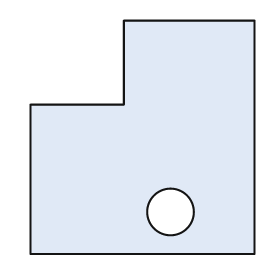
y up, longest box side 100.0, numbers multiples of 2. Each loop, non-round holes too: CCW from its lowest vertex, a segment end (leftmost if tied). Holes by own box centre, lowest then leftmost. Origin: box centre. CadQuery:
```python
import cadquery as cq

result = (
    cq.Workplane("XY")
    .moveTo(-48.0, -50.0)
    .lineTo(48.0, -50.0)
    .lineTo(48.0, 50.0)
    .lineTo(-8.0, 50.0)
    .lineTo(-8.0, 14.0)
    .lineTo(-48.0, 14.0)
    .close()
    .moveTo(12.0, -32.0)
    .circle(10.0)
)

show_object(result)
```